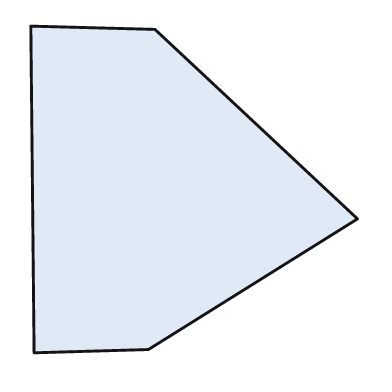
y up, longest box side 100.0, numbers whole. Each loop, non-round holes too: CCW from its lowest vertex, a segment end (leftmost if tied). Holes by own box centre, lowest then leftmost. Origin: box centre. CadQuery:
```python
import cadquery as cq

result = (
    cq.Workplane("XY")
    .moveTo(-49.0, -50.0)
    .lineTo(-14.0, -49.0)
    .lineTo(50.0, -9.0)
    .lineTo(-12.0, 49.0)
    .lineTo(-50.0, 50.0)
    .close()
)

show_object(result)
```